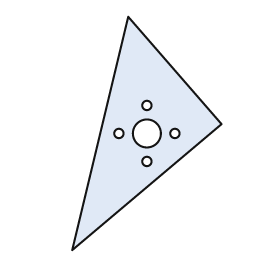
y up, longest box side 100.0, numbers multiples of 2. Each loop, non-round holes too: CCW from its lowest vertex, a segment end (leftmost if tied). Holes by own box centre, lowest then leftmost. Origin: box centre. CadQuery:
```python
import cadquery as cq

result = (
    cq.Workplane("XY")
    .moveTo(-32.0, -50.0)
    .lineTo(32.0, 4.0)
    .lineTo(-8.0, 50.0)
    .close()
    .moveTo(0.0, -12.0)
    .circle(2.0)
    .moveTo(-12.0, 0.0)
    .circle(2.0)
    .moveTo(0.0, 0.0)
    .circle(6.0)
    .moveTo(12.0, 0.0)
    .circle(2.0)
    .moveTo(0.0, 12.0)
    .circle(2.0)
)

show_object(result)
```